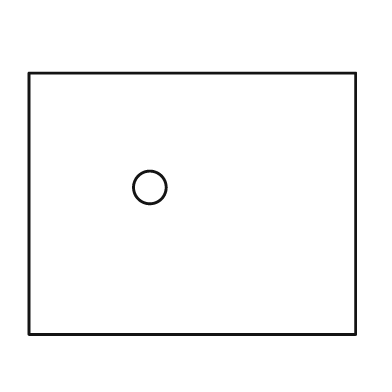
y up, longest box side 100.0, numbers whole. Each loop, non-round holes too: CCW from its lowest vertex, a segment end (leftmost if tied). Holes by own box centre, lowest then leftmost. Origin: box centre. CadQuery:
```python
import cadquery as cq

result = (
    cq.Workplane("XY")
    .moveTo(-50.0, -40.0)
    .lineTo(50.0, -40.0)
    .lineTo(50.0, 40.0)
    .lineTo(-50.0, 40.0)
    .close()
    .moveTo(-13.0, 5.0)
    .circle(5.0)
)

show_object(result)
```